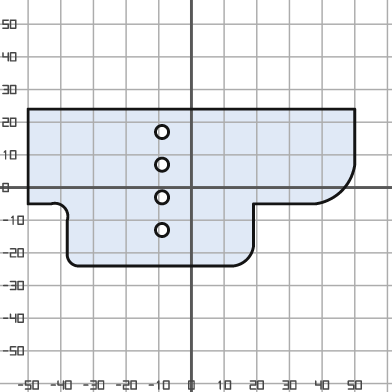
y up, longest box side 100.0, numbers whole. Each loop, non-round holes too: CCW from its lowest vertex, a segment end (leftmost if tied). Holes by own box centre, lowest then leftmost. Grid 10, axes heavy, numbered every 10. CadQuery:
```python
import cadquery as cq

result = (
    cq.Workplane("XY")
    .moveTo(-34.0, -24.0)
    .lineTo(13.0, -24.0)
    .threePointArc((17.0, -22.0), (19.0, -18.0))
    .lineTo(19.0, -5.0)
    .lineTo(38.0, -5.0)
    .threePointArc((46.0, -1.0), (50.0, 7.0))
    .lineTo(50.0, 24.0)
    .lineTo(-50.0, 24.0)
    .lineTo(-50.0, -5.0)
    .lineTo(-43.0, -5.0)
    .threePointArc((-39.0, -6.0), (-38.0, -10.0))
    .lineTo(-38.0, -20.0)
    .threePointArc((-37.0, -23.0), (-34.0, -24.0))
    .close()
    .moveTo(-9.0, -13.0)
    .circle(2.0)
    .moveTo(-9.0, -3.0)
    .circle(2.0)
    .moveTo(-9.0, 7.0)
    .circle(2.0)
    .moveTo(-9.0, 17.0)
    .circle(2.0)
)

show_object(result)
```